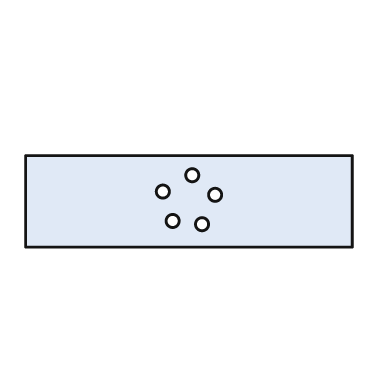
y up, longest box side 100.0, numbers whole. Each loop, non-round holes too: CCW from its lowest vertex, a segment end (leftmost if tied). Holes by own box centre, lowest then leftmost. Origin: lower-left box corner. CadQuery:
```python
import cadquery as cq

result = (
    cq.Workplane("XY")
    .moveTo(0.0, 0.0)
    .lineTo(100.0, 0.0)
    .lineTo(100.0, 28.0)
    .lineTo(0.0, 28.0)
    .close()
    .moveTo(54.0, 7.0)
    .circle(2.0)
    .moveTo(45.0, 8.0)
    .circle(2.0)
    .moveTo(58.0, 16.0)
    .circle(2.0)
    .moveTo(42.0, 17.0)
    .circle(2.0)
    .moveTo(51.0, 22.0)
    .circle(2.0)
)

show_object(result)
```